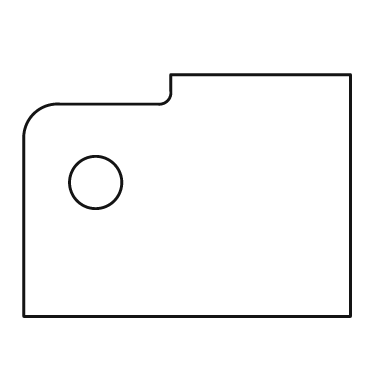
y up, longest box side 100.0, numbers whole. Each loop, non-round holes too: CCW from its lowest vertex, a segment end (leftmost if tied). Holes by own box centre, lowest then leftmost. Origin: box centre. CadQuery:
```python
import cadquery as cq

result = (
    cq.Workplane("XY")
    .moveTo(-50.0, -37.0)
    .lineTo(50.0, -37.0)
    .lineTo(50.0, 37.0)
    .lineTo(-5.0, 37.0)
    .lineTo(-5.0, 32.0)
    .threePointArc((-6.0, 29.0), (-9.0, 28.0))
    .lineTo(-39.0, 28.0)
    .threePointArc((-47.0, 25.0), (-50.0, 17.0))
    .close()
    .moveTo(-28.0, 4.0)
    .circle(8.0)
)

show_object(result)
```